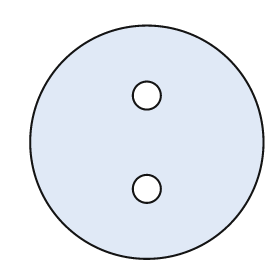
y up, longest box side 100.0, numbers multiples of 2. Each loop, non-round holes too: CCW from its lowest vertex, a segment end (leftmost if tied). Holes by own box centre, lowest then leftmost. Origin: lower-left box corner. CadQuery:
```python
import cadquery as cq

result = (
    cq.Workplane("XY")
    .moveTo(50.0, 50.0)
    .circle(50.0)
    .moveTo(50.0, 30.0)
    .circle(6.0)
    .moveTo(50.0, 70.0)
    .circle(6.0)
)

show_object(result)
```